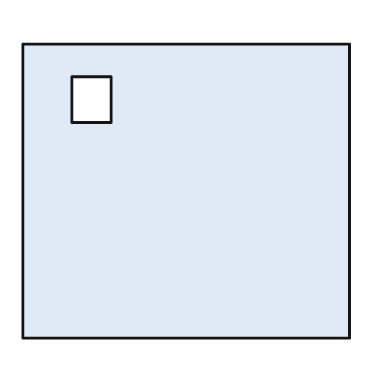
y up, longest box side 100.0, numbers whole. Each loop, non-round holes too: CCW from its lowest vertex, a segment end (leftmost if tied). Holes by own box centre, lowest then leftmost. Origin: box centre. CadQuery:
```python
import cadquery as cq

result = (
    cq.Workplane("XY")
    .moveTo(-50.0, -45.0)
    .lineTo(50.0, -45.0)
    .lineTo(50.0, 45.0)
    .lineTo(-50.0, 45.0)
    .close()
    .moveTo(-35.0, 21.0)
    .lineTo(-23.0, 21.0)
    .lineTo(-23.0, 35.0)
    .lineTo(-35.0, 35.0)
    .close()
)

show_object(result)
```